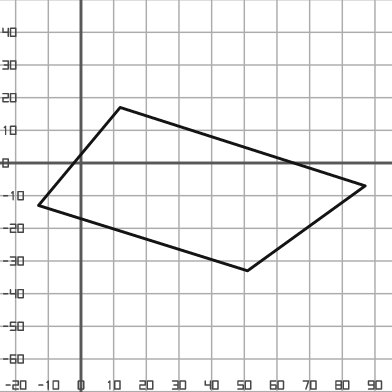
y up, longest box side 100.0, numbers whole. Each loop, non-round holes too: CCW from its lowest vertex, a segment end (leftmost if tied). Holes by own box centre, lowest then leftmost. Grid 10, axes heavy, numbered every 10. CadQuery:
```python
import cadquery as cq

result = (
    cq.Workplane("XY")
    .moveTo(51.0, -33.0)
    .lineTo(87.0, -7.0)
    .lineTo(12.0, 17.0)
    .lineTo(-13.0, -13.0)
    .close()
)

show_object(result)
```